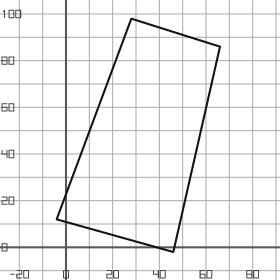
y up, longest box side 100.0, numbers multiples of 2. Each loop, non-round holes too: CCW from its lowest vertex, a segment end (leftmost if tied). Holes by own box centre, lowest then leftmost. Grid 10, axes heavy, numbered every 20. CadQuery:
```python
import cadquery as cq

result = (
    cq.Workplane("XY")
    .moveTo(46.0, -2.0)
    .lineTo(66.0, 86.0)
    .lineTo(28.0, 98.0)
    .lineTo(-4.0, 12.0)
    .close()
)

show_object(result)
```